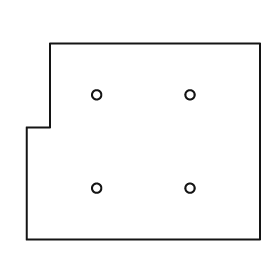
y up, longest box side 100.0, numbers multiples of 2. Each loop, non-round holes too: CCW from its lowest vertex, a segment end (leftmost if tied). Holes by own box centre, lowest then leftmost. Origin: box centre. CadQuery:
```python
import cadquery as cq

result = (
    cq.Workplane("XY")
    .moveTo(-50.0, -42.0)
    .lineTo(50.0, -42.0)
    .lineTo(50.0, 42.0)
    .lineTo(-40.0, 42.0)
    .lineTo(-40.0, 6.0)
    .lineTo(-50.0, 6.0)
    .close()
    .moveTo(-20.0, -20.0)
    .circle(2.0)
    .moveTo(20.0, -20.0)
    .circle(2.0)
    .moveTo(-20.0, 20.0)
    .circle(2.0)
    .moveTo(20.0, 20.0)
    .circle(2.0)
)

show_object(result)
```